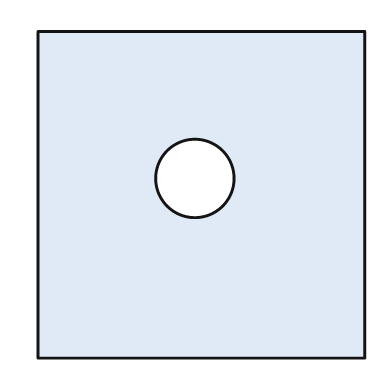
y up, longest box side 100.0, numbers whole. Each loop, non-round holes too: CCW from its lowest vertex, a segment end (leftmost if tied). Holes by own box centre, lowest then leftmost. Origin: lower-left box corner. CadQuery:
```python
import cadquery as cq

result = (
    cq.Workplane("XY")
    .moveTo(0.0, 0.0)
    .lineTo(100.0, 0.0)
    .lineTo(100.0, 100.0)
    .lineTo(0.0, 100.0)
    .close()
    .moveTo(48.0, 55.0)
    .circle(12.0)
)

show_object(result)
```